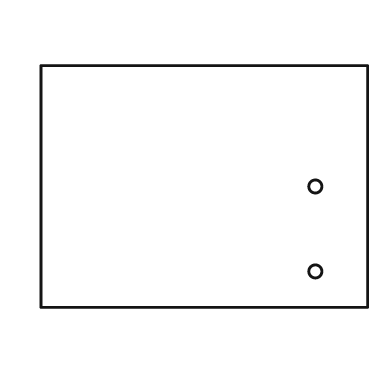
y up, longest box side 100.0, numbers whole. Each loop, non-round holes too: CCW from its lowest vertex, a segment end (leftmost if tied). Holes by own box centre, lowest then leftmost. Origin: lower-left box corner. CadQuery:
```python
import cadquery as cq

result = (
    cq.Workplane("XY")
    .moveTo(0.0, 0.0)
    .lineTo(100.0, 0.0)
    .lineTo(100.0, 74.0)
    .lineTo(0.0, 74.0)
    .close()
    .moveTo(84.0, 11.0)
    .circle(2.0)
    .moveTo(84.0, 37.0)
    .circle(2.0)
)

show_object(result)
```